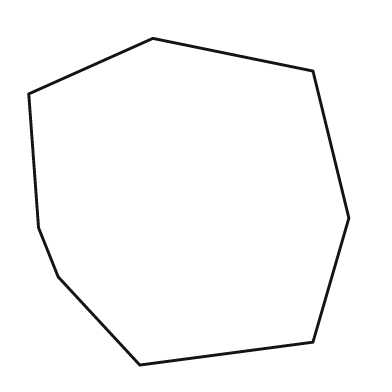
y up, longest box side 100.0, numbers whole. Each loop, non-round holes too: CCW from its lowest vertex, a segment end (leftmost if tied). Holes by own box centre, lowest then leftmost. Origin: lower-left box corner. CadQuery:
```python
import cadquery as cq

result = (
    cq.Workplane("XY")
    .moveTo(34.0, 0.0)
    .lineTo(87.0, 7.0)
    .lineTo(98.0, 45.0)
    .lineTo(87.0, 90.0)
    .lineTo(38.0, 100.0)
    .lineTo(0.0, 83.0)
    .lineTo(3.0, 42.0)
    .lineTo(9.0, 27.0)
    .close()
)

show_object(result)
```